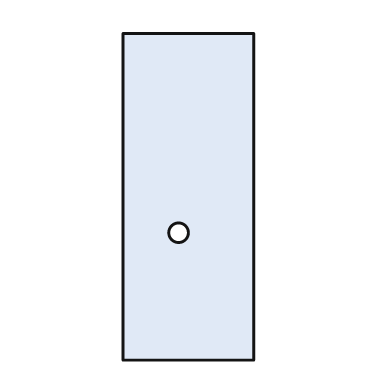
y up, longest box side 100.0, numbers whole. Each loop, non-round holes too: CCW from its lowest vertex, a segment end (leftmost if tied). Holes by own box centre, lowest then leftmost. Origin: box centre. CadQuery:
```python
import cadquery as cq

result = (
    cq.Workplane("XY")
    .moveTo(-20.0, -50.0)
    .lineTo(20.0, -50.0)
    .lineTo(20.0, 50.0)
    .lineTo(-20.0, 50.0)
    .close()
    .moveTo(-3.0, -11.0)
    .circle(3.0)
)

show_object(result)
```